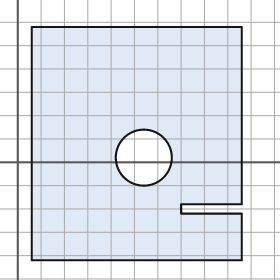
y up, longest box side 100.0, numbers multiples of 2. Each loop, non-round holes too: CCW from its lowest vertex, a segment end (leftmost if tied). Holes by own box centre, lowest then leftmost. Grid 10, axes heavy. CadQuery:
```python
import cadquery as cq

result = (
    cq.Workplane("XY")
    .moveTo(6.0, -42.0)
    .lineTo(96.0, -42.0)
    .lineTo(96.0, -22.0)
    .lineTo(70.0, -22.0)
    .lineTo(70.0, -18.0)
    .lineTo(96.0, -18.0)
    .lineTo(96.0, 58.0)
    .lineTo(6.0, 58.0)
    .close()
    .moveTo(54.0, 2.0)
    .circle(12.0)
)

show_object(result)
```